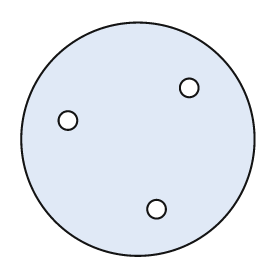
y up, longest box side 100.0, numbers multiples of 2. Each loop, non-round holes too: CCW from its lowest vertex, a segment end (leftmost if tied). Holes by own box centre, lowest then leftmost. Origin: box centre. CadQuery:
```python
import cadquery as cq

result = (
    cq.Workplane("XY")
    .moveTo(0.0, 0.0)
    .circle(50.0)
    .moveTo(8.0, -30.0)
    .circle(4.0)
    .moveTo(-30.0, 8.0)
    .circle(4.0)
    .moveTo(22.0, 22.0)
    .circle(4.0)
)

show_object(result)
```